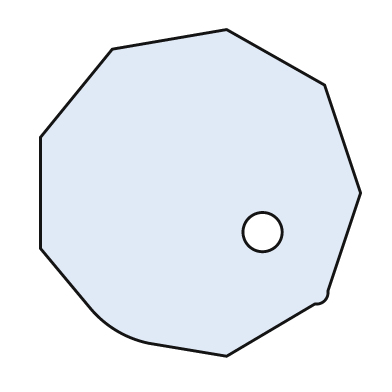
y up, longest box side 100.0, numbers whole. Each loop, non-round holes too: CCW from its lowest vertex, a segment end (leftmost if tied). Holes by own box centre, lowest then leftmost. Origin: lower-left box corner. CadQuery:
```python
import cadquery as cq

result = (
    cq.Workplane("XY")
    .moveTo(57.0, 0.0)
    .lineTo(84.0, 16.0)
    .threePointArc((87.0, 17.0), (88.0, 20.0))
    .lineTo(98.0, 50.0)
    .lineTo(87.0, 83.0)
    .lineTo(57.0, 100.0)
    .lineTo(22.0, 94.0)
    .lineTo(0.0, 67.0)
    .lineTo(0.0, 33.0)
    .lineTo(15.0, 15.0)
    .threePointArc((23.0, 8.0), (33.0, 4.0))
    .close()
    .moveTo(68.0, 38.0)
    .circle(6.0)
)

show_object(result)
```